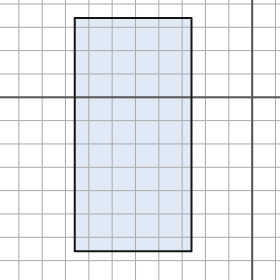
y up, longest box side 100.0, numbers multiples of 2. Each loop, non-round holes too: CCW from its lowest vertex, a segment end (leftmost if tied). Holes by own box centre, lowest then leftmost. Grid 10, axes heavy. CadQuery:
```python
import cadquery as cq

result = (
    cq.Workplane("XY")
    .moveTo(-76.0, -66.0)
    .lineTo(-26.0, -66.0)
    .lineTo(-26.0, 34.0)
    .lineTo(-76.0, 34.0)
    .close()
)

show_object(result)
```